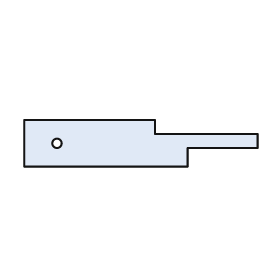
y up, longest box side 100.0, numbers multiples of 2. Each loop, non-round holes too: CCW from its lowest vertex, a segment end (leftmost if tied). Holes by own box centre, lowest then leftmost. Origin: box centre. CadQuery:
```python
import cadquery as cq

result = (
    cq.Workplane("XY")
    .moveTo(-50.0, -10.0)
    .lineTo(20.0, -10.0)
    .lineTo(20.0, -2.0)
    .lineTo(50.0, -2.0)
    .lineTo(50.0, 4.0)
    .lineTo(6.0, 4.0)
    .lineTo(6.0, 10.0)
    .lineTo(-50.0, 10.0)
    .close()
    .moveTo(-36.0, 0.0)
    .circle(2.0)
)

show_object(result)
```